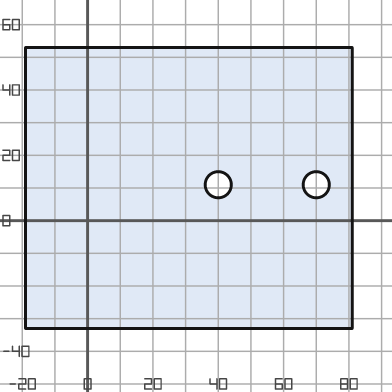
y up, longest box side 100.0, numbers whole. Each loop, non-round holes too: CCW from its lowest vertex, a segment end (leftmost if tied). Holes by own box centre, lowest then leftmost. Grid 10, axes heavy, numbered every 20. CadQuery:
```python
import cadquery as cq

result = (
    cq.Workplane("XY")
    .moveTo(-19.0, -33.0)
    .lineTo(81.0, -33.0)
    .lineTo(81.0, 53.0)
    .lineTo(-19.0, 53.0)
    .close()
    .moveTo(40.0, 11.0)
    .circle(4.0)
    .moveTo(70.0, 11.0)
    .circle(4.0)
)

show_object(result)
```